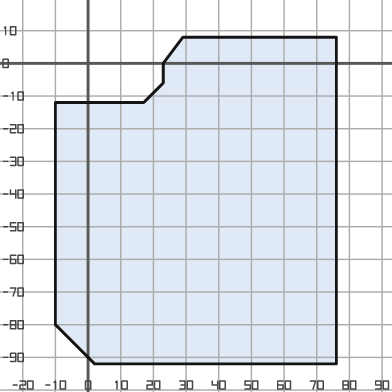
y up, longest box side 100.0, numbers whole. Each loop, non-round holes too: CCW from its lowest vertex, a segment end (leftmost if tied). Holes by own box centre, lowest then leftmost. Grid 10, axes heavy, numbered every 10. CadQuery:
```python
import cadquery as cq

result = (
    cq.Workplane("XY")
    .moveTo(2.0, -92.0)
    .lineTo(76.0, -92.0)
    .lineTo(76.0, 8.0)
    .lineTo(29.0, 8.0)
    .lineTo(23.0, 0.0)
    .lineTo(23.0, -6.0)
    .lineTo(17.0, -12.0)
    .lineTo(-10.0, -12.0)
    .lineTo(-10.0, -80.0)
    .close()
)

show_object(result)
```